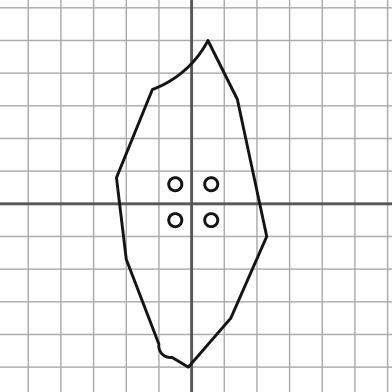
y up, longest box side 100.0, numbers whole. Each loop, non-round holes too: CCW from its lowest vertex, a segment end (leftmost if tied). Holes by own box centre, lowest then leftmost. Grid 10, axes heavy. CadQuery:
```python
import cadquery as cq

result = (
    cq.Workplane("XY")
    .moveTo(-1.0, -50.0)
    .lineTo(12.0, -35.0)
    .lineTo(23.0, -10.0)
    .lineTo(14.0, 32.0)
    .lineTo(5.0, 50.0)
    .threePointArc((-2.0, 41.0), (-12.0, 35.0))
    .lineTo(-23.0, 8.0)
    .lineTo(-20.0, -17.0)
    .lineTo(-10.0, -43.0)
    .threePointArc((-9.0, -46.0), (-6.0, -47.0))
    .close()
    .moveTo(-5.0, -5.0)
    .circle(2.0)
    .moveTo(6.0, -5.0)
    .circle(2.0)
    .moveTo(-5.0, 6.0)
    .circle(2.0)
    .moveTo(6.0, 6.0)
    .circle(2.0)
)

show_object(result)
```